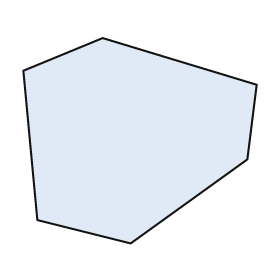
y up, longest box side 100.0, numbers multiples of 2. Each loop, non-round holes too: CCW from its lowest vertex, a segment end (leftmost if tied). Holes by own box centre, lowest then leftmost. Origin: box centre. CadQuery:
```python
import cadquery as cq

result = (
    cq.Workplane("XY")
    .moveTo(-4.0, -44.0)
    .lineTo(46.0, -8.0)
    .lineTo(50.0, 24.0)
    .lineTo(-16.0, 44.0)
    .lineTo(-50.0, 30.0)
    .lineTo(-44.0, -34.0)
    .close()
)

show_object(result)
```